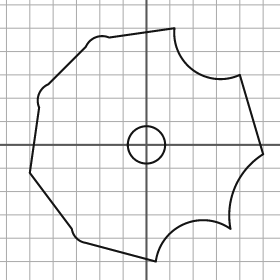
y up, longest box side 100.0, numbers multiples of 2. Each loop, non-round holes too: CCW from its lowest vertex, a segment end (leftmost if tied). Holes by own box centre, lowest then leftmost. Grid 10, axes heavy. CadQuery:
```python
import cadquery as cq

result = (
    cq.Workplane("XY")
    .moveTo(4.0, -50.0)
    .threePointArc((16.0, -34.0), (36.0, -36.0))
    .threePointArc((38.0, -18.0), (50.0, -4.0))
    .lineTo(40.0, 30.0)
    .threePointArc((20.0, 32.0), (12.0, 50.0))
    .lineTo(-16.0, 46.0)
    .threePointArc((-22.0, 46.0), (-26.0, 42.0))
    .lineTo(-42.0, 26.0)
    .threePointArc((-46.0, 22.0), (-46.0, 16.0))
    .lineTo(-50.0, -12.0)
    .lineTo(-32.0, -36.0)
    .threePointArc((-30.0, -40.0), (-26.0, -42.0))
    .close()
    .moveTo(0.0, 0.0)
    .circle(8.0)
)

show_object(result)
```